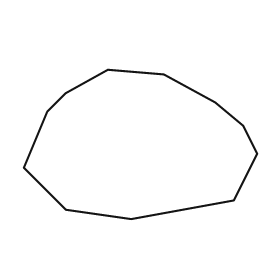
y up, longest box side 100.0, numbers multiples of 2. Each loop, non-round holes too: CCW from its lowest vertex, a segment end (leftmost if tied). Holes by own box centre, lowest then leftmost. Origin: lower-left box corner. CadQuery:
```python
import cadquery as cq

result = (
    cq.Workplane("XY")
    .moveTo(46.0, 0.0)
    .lineTo(90.0, 8.0)
    .lineTo(100.0, 28.0)
    .lineTo(94.0, 40.0)
    .lineTo(82.0, 50.0)
    .lineTo(60.0, 62.0)
    .lineTo(36.0, 64.0)
    .lineTo(18.0, 54.0)
    .lineTo(10.0, 46.0)
    .lineTo(0.0, 22.0)
    .lineTo(18.0, 4.0)
    .close()
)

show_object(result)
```